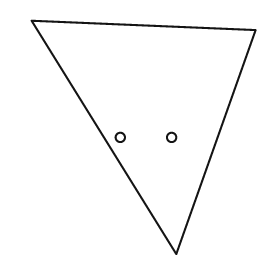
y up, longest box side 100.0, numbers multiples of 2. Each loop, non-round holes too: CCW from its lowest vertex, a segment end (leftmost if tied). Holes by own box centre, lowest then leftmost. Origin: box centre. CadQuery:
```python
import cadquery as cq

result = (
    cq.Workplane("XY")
    .moveTo(14.0, -50.0)
    .lineTo(48.0, 46.0)
    .lineTo(-48.0, 50.0)
    .close()
    .moveTo(-10.0, 0.0)
    .circle(2.0)
    .moveTo(12.0, 0.0)
    .circle(2.0)
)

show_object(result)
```